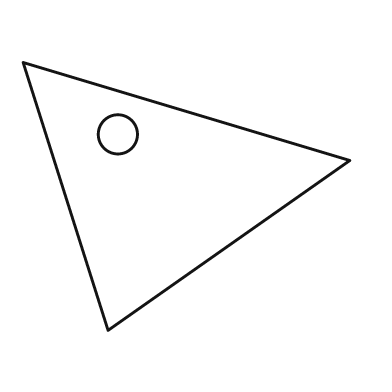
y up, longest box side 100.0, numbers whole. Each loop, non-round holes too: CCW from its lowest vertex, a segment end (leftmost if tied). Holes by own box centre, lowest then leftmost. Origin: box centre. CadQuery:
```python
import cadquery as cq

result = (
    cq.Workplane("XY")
    .moveTo(-24.0, -41.0)
    .lineTo(50.0, 11.0)
    .lineTo(-50.0, 41.0)
    .close()
    .moveTo(-21.0, 19.0)
    .circle(6.0)
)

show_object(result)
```